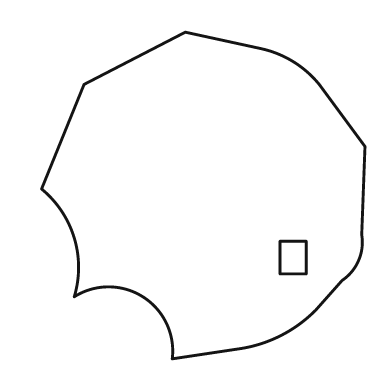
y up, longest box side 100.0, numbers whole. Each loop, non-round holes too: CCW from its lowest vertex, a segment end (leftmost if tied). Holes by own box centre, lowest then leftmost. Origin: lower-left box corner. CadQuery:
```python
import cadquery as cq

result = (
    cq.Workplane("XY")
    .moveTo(40.0, 0.0)
    .lineTo(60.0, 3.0)
    .threePointArc((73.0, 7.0), (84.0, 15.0))
    .lineTo(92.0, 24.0)
    .threePointArc((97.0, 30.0), (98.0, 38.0))
    .lineTo(99.0, 65.0)
    .lineTo(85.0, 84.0)
    .threePointArc((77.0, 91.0), (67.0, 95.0))
    .lineTo(44.0, 100.0)
    .lineTo(13.0, 84.0)
    .lineTo(0.0, 52.0)
    .threePointArc((10.0, 37.0), (10.0, 19.0))
    .threePointArc((31.0, 19.0), (40.0, 0.0))
    .close()
    .moveTo(73.0, 26.0)
    .lineTo(81.0, 26.0)
    .lineTo(81.0, 36.0)
    .lineTo(73.0, 36.0)
    .close()
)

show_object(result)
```